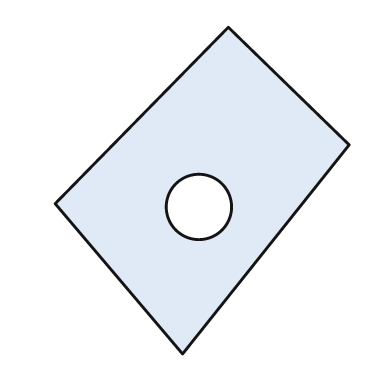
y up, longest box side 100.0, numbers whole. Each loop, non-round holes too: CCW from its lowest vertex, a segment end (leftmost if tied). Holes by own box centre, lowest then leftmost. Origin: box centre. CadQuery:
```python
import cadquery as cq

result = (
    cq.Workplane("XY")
    .moveTo(-6.0, -50.0)
    .lineTo(45.0, 14.0)
    .lineTo(8.0, 50.0)
    .lineTo(-45.0, -4.0)
    .close()
    .moveTo(-1.0, -5.0)
    .circle(10.0)
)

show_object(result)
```